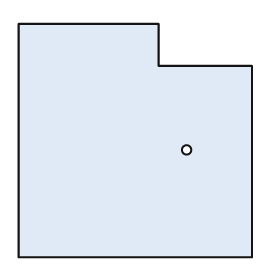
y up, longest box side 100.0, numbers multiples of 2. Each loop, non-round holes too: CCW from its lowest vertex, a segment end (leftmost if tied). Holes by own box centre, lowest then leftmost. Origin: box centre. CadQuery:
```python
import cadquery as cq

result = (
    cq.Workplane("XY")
    .moveTo(-50.0, -50.0)
    .lineTo(50.0, -50.0)
    .lineTo(50.0, 32.0)
    .lineTo(10.0, 32.0)
    .lineTo(10.0, 50.0)
    .lineTo(-50.0, 50.0)
    .close()
    .moveTo(22.0, -4.0)
    .circle(2.0)
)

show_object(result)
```